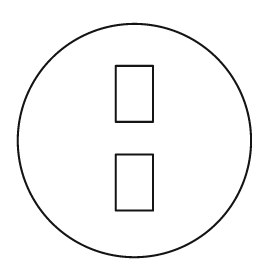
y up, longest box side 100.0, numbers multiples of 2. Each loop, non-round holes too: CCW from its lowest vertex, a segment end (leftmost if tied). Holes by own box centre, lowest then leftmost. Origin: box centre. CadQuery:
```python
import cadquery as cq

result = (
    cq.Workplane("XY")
    .moveTo(0.0, 0.0)
    .circle(50.0)
    .moveTo(-8.0, -30.0)
    .lineTo(8.0, -30.0)
    .lineTo(8.0, -6.0)
    .lineTo(-8.0, -6.0)
    .close()
    .moveTo(-8.0, 8.0)
    .lineTo(8.0, 8.0)
    .lineTo(8.0, 32.0)
    .lineTo(-8.0, 32.0)
    .close()
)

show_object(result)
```